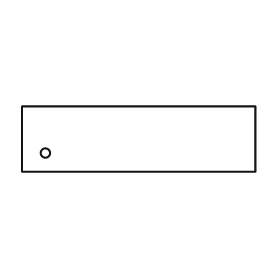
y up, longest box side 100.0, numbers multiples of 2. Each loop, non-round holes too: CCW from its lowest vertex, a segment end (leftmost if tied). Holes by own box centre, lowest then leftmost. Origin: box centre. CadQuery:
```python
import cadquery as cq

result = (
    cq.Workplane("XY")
    .moveTo(-50.0, -14.0)
    .lineTo(50.0, -14.0)
    .lineTo(50.0, 14.0)
    .lineTo(-50.0, 14.0)
    .close()
    .moveTo(-40.0, -6.0)
    .circle(2.0)
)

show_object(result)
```